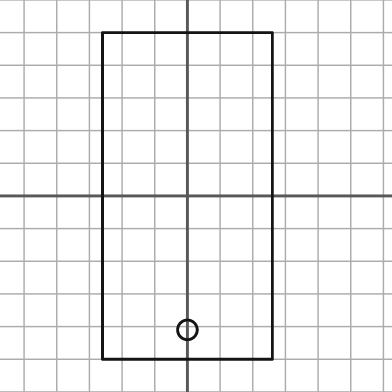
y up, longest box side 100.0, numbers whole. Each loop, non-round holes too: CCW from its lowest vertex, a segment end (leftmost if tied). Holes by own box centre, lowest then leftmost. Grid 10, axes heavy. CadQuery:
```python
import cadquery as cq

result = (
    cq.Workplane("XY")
    .moveTo(-26.0, -50.0)
    .lineTo(26.0, -50.0)
    .lineTo(26.0, 50.0)
    .lineTo(-26.0, 50.0)
    .close()
    .moveTo(0.0, -41.0)
    .circle(3.0)
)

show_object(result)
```